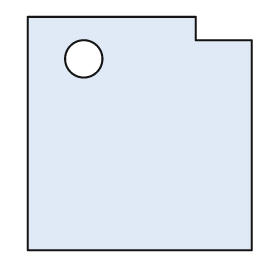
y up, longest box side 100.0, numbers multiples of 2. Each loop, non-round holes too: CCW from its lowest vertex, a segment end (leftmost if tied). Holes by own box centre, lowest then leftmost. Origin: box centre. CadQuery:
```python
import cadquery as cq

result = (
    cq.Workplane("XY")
    .moveTo(-48.0, -50.0)
    .lineTo(48.0, -50.0)
    .lineTo(48.0, 40.0)
    .lineTo(24.0, 40.0)
    .lineTo(24.0, 50.0)
    .lineTo(-48.0, 50.0)
    .close()
    .moveTo(-24.0, 32.0)
    .circle(8.0)
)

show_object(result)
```